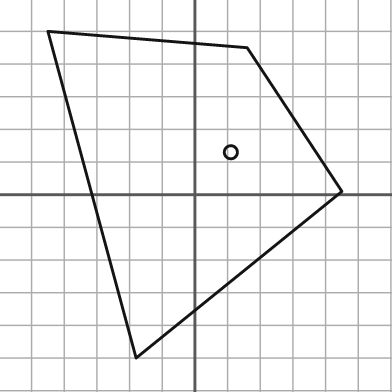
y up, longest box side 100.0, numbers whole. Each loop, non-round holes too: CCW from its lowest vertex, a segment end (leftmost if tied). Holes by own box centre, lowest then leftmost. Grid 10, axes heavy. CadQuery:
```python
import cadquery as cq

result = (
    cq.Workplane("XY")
    .moveTo(-18.0, -50.0)
    .lineTo(45.0, 1.0)
    .lineTo(16.0, 45.0)
    .lineTo(-45.0, 50.0)
    .close()
    .moveTo(11.0, 13.0)
    .circle(2.0)
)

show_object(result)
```